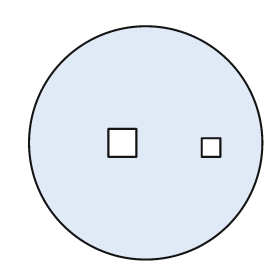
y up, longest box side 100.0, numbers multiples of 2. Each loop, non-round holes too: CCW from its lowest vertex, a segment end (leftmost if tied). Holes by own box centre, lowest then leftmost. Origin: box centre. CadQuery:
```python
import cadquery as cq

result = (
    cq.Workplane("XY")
    .moveTo(0.0, 0.0)
    .circle(50.0)
    .moveTo(24.0, -6.0)
    .lineTo(32.0, -6.0)
    .lineTo(32.0, 2.0)
    .lineTo(24.0, 2.0)
    .close()
    .moveTo(-16.0, -6.0)
    .lineTo(-4.0, -6.0)
    .lineTo(-4.0, 6.0)
    .lineTo(-16.0, 6.0)
    .close()
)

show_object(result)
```